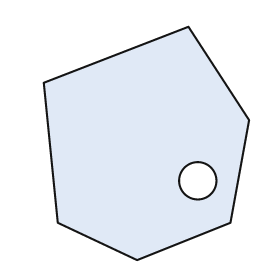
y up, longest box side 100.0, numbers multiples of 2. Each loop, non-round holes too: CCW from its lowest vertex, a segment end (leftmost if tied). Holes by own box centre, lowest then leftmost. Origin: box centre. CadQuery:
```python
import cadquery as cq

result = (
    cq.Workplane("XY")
    .moveTo(-4.0, -50.0)
    .lineTo(36.0, -34.0)
    .lineTo(44.0, 10.0)
    .lineTo(18.0, 50.0)
    .lineTo(-44.0, 26.0)
    .lineTo(-38.0, -34.0)
    .close()
    .moveTo(22.0, -16.0)
    .circle(8.0)
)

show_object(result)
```